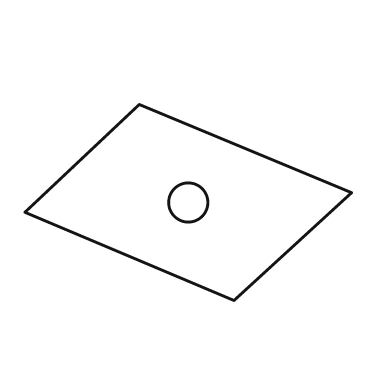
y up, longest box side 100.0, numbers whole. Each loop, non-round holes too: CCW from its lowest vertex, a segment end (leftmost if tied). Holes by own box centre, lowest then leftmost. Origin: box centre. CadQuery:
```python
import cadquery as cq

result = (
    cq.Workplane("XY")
    .moveTo(14.0, -30.0)
    .lineTo(50.0, 3.0)
    .lineTo(-15.0, 30.0)
    .lineTo(-50.0, -3.0)
    .close()
    .moveTo(0.0, 0.0)
    .circle(6.0)
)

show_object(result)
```